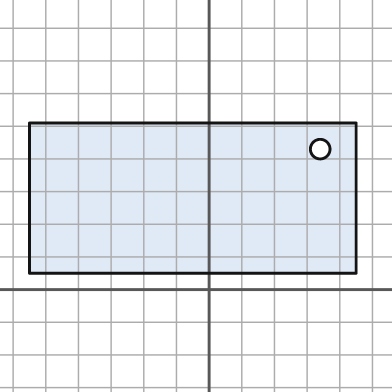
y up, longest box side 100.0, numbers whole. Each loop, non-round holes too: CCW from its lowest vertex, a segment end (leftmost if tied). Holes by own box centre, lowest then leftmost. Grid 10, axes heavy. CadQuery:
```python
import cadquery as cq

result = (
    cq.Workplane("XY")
    .moveTo(-55.0, 5.0)
    .lineTo(45.0, 5.0)
    .lineTo(45.0, 51.0)
    .lineTo(-55.0, 51.0)
    .close()
    .moveTo(34.0, 43.0)
    .circle(3.0)
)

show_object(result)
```